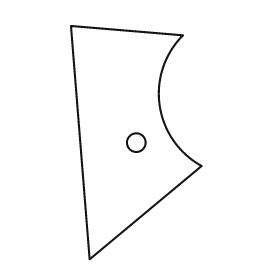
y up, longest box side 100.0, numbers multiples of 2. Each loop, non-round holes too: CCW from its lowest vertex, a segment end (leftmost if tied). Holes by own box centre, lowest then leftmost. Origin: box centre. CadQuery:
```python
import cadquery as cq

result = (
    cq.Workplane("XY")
    .moveTo(-20.0, -50.0)
    .lineTo(28.0, -10.0)
    .threePointArc((10.0, 16.0), (20.0, 46.0))
    .lineTo(-28.0, 50.0)
    .close()
    .moveTo(0.0, 0.0)
    .circle(4.0)
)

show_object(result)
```